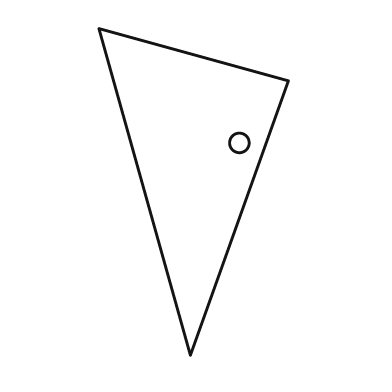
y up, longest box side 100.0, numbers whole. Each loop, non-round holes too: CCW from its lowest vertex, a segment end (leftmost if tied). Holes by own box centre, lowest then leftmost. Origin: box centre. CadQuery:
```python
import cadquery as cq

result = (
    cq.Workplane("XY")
    .moveTo(-1.0, -50.0)
    .lineTo(29.0, 34.0)
    .lineTo(-29.0, 50.0)
    .close()
    .moveTo(14.0, 15.0)
    .circle(3.0)
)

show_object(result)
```